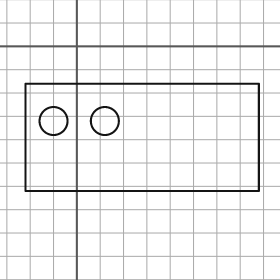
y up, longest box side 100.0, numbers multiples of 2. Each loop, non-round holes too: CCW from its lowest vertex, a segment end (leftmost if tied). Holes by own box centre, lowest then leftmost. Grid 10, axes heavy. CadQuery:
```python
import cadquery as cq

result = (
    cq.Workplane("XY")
    .moveTo(-22.0, -62.0)
    .lineTo(78.0, -62.0)
    .lineTo(78.0, -16.0)
    .lineTo(-22.0, -16.0)
    .close()
    .moveTo(-10.0, -32.0)
    .circle(6.0)
    .moveTo(12.0, -32.0)
    .circle(6.0)
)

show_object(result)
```